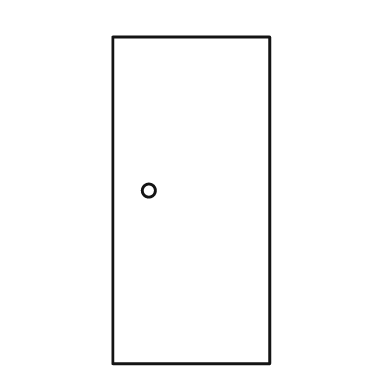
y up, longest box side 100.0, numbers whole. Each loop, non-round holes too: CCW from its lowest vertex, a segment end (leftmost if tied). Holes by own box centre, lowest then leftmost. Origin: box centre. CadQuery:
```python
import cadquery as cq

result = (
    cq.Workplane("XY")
    .moveTo(-24.0, -50.0)
    .lineTo(24.0, -50.0)
    .lineTo(24.0, 50.0)
    .lineTo(-24.0, 50.0)
    .close()
    .moveTo(-13.0, 3.0)
    .circle(2.0)
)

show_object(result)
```